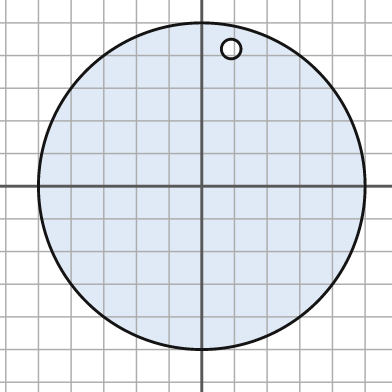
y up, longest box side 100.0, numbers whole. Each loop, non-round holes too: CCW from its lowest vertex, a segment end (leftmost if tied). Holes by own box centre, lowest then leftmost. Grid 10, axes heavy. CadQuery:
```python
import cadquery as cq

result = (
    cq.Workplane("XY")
    .moveTo(0.0, 0.0)
    .circle(50.0)
    .moveTo(9.0, 42.0)
    .circle(3.0)
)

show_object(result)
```